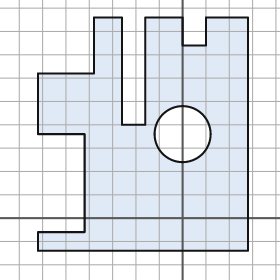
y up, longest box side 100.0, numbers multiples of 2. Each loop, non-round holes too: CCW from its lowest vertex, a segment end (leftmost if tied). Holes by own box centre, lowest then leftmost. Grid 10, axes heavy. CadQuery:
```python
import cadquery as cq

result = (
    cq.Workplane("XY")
    .moveTo(-62.0, -14.0)
    .lineTo(28.0, -14.0)
    .lineTo(28.0, 86.0)
    .lineTo(10.0, 86.0)
    .lineTo(10.0, 74.0)
    .lineTo(0.0, 74.0)
    .lineTo(0.0, 86.0)
    .lineTo(-16.0, 86.0)
    .lineTo(-16.0, 40.0)
    .lineTo(-26.0, 40.0)
    .lineTo(-26.0, 86.0)
    .lineTo(-38.0, 86.0)
    .lineTo(-38.0, 62.0)
    .lineTo(-62.0, 62.0)
    .lineTo(-62.0, 36.0)
    .lineTo(-42.0, 36.0)
    .lineTo(-42.0, -6.0)
    .lineTo(-62.0, -6.0)
    .close()
    .moveTo(0.0, 36.0)
    .circle(12.0)
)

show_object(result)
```